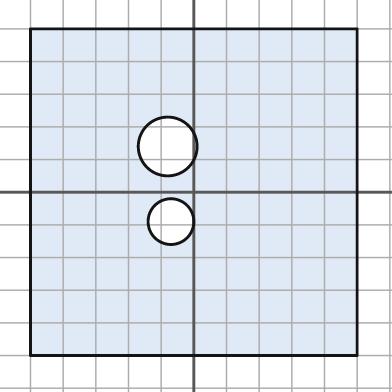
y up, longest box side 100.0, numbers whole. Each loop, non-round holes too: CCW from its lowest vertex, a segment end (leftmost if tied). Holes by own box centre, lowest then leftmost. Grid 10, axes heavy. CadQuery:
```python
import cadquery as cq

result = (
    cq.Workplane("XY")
    .moveTo(-50.0, -50.0)
    .lineTo(50.0, -50.0)
    .lineTo(50.0, 50.0)
    .lineTo(-50.0, 50.0)
    .close()
    .moveTo(-7.0, -9.0)
    .circle(7.0)
    .moveTo(-8.0, 14.0)
    .circle(9.0)
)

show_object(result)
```